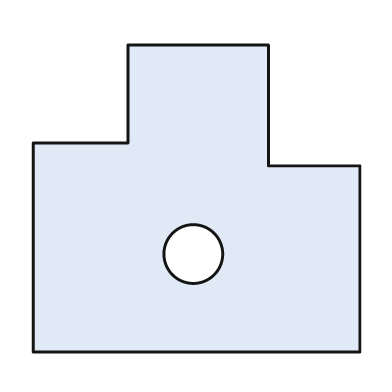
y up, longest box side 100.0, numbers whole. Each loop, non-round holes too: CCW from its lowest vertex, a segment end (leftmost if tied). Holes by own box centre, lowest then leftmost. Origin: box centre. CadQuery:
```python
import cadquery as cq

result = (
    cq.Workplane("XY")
    .moveTo(-50.0, -47.0)
    .lineTo(50.0, -47.0)
    .lineTo(50.0, 10.0)
    .lineTo(22.0, 10.0)
    .lineTo(22.0, 47.0)
    .lineTo(-21.0, 47.0)
    .lineTo(-21.0, 17.0)
    .lineTo(-50.0, 17.0)
    .close()
    .moveTo(-1.0, -17.0)
    .circle(9.0)
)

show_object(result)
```